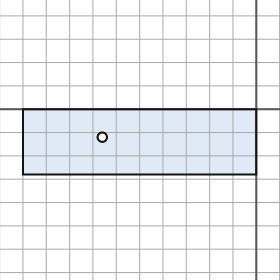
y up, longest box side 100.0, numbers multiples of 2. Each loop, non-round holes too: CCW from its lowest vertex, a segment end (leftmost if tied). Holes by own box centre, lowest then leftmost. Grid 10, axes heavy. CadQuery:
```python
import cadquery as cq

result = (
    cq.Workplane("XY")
    .moveTo(-100.0, -28.0)
    .lineTo(0.0, -28.0)
    .lineTo(0.0, 0.0)
    .lineTo(-100.0, 0.0)
    .close()
    .moveTo(-66.0, -12.0)
    .circle(2.0)
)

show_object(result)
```